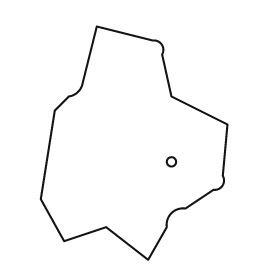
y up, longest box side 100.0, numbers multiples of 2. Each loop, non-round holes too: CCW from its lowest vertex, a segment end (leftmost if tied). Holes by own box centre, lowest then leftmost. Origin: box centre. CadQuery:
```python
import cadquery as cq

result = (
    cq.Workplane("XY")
    .moveTo(6.0, -50.0)
    .lineTo(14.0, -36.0)
    .threePointArc((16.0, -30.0), (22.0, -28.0))
    .lineTo(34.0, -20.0)
    .threePointArc((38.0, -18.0), (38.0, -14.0))
    .lineTo(40.0, 8.0)
    .lineTo(16.0, 20.0)
    .lineTo(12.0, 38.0)
    .threePointArc((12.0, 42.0), (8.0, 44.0))
    .lineTo(-16.0, 50.0)
    .lineTo(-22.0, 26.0)
    .threePointArc((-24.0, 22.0), (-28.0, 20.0))
    .lineTo(-34.0, 14.0)
    .lineTo(-40.0, -24.0)
    .lineTo(-30.0, -42.0)
    .lineTo(-12.0, -36.0)
    .close()
    .moveTo(16.0, -8.0)
    .circle(2.0)
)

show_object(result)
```